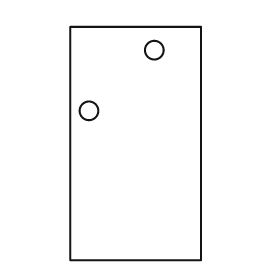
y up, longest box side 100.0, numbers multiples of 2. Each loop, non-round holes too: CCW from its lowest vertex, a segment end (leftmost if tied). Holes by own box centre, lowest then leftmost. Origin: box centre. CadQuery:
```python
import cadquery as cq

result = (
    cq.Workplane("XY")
    .moveTo(-28.0, -50.0)
    .lineTo(28.0, -50.0)
    .lineTo(28.0, 50.0)
    .lineTo(-28.0, 50.0)
    .close()
    .moveTo(-20.0, 14.0)
    .circle(4.0)
    .moveTo(8.0, 40.0)
    .circle(4.0)
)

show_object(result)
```